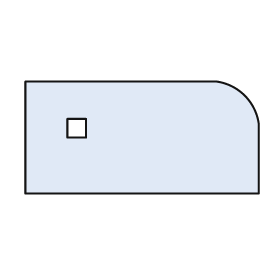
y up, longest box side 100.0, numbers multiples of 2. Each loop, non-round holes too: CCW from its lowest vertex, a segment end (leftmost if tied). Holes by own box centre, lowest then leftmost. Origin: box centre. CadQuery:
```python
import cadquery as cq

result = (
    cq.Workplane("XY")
    .moveTo(-50.0, -24.0)
    .lineTo(50.0, -24.0)
    .lineTo(50.0, 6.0)
    .threePointArc((44.0, 18.0), (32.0, 24.0))
    .lineTo(-50.0, 24.0)
    .close()
    .moveTo(-32.0, 0.0)
    .lineTo(-24.0, 0.0)
    .lineTo(-24.0, 8.0)
    .lineTo(-32.0, 8.0)
    .close()
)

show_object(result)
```